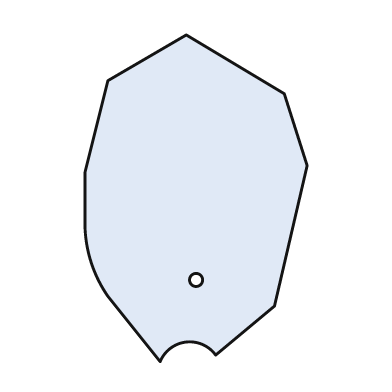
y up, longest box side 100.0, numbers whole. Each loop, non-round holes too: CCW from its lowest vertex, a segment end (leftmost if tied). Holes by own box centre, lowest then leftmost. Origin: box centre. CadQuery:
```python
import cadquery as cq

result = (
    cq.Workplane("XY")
    .moveTo(-11.0, -50.0)
    .threePointArc((-3.0, -44.0), (6.0, -48.0))
    .lineTo(24.0, -33.0)
    .lineTo(34.0, 10.0)
    .lineTo(27.0, 32.0)
    .lineTo(-3.0, 50.0)
    .lineTo(-27.0, 36.0)
    .lineTo(-34.0, 8.0)
    .lineTo(-34.0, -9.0)
    .threePointArc((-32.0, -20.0), (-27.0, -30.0))
    .close()
    .moveTo(0.0, -25.0)
    .circle(2.0)
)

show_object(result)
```